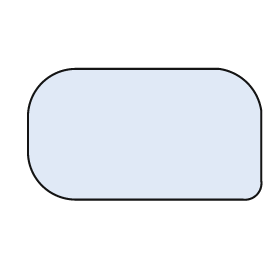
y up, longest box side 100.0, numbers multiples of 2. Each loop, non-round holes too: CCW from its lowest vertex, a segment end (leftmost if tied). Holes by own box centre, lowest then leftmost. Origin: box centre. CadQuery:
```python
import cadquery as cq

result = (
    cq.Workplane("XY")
    .moveTo(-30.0, -28.0)
    .lineTo(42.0, -28.0)
    .threePointArc((48.0, -26.0), (50.0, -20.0))
    .lineTo(50.0, 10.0)
    .threePointArc((44.0, 22.0), (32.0, 28.0))
    .lineTo(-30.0, 28.0)
    .threePointArc((-44.0, 22.0), (-50.0, 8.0))
    .lineTo(-50.0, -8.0)
    .threePointArc((-44.0, -22.0), (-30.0, -28.0))
    .close()
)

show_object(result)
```